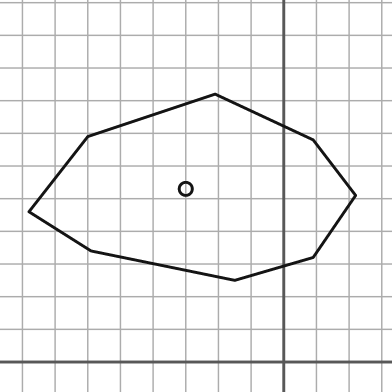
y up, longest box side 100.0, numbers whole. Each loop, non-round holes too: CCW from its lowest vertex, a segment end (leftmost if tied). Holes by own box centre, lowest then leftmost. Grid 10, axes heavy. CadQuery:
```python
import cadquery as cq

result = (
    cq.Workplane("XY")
    .moveTo(-15.0, 25.0)
    .lineTo(9.0, 32.0)
    .lineTo(22.0, 51.0)
    .lineTo(9.0, 68.0)
    .lineTo(-21.0, 82.0)
    .lineTo(-60.0, 69.0)
    .lineTo(-78.0, 46.0)
    .lineTo(-59.0, 34.0)
    .close()
    .moveTo(-30.0, 53.0)
    .circle(2.0)
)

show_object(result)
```